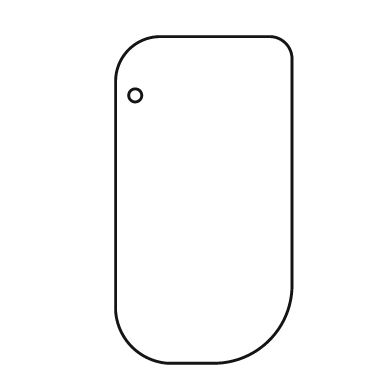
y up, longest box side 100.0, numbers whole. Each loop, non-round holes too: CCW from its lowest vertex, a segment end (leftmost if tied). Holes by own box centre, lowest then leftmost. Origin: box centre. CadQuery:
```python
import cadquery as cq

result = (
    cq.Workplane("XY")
    .moveTo(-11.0, -50.0)
    .lineTo(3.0, -50.0)
    .threePointArc((20.0, -43.0), (27.0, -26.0))
    .lineTo(27.0, 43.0)
    .threePointArc((25.0, 48.0), (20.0, 50.0))
    .lineTo(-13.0, 50.0)
    .threePointArc((-23.0, 46.0), (-27.0, 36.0))
    .lineTo(-27.0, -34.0)
    .threePointArc((-22.0, -45.0), (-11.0, -50.0))
    .close()
    .moveTo(-21.0, 32.0)
    .circle(2.0)
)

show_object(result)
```